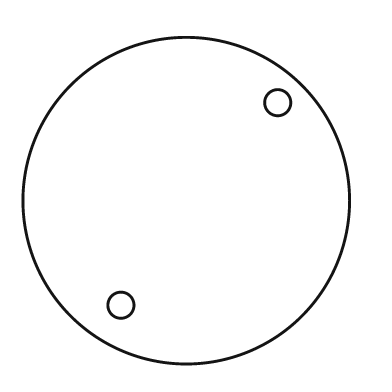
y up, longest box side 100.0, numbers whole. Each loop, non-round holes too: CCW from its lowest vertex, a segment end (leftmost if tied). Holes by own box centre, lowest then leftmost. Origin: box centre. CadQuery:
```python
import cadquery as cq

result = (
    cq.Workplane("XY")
    .moveTo(0.0, 0.0)
    .circle(50.0)
    .moveTo(-20.0, -32.0)
    .circle(4.0)
    .moveTo(28.0, 30.0)
    .circle(4.0)
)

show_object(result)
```